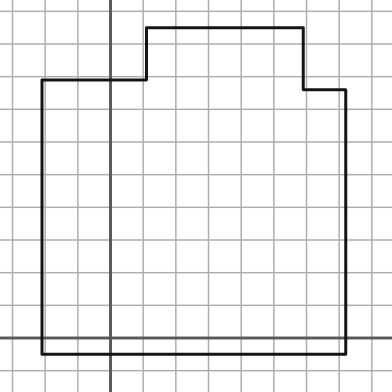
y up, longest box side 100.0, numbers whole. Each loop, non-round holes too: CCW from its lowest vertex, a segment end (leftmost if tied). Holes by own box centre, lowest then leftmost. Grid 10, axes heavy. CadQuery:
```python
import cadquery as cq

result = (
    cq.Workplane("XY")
    .moveTo(-21.0, -5.0)
    .lineTo(72.0, -5.0)
    .lineTo(72.0, 76.0)
    .lineTo(59.0, 76.0)
    .lineTo(59.0, 95.0)
    .lineTo(11.0, 95.0)
    .lineTo(11.0, 79.0)
    .lineTo(-21.0, 79.0)
    .close()
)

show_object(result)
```